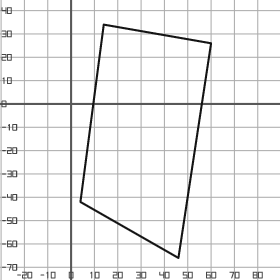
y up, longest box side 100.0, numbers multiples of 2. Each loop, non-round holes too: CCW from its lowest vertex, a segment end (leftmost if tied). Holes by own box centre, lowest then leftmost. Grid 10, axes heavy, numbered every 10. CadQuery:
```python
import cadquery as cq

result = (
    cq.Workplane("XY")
    .moveTo(46.0, -66.0)
    .lineTo(60.0, 26.0)
    .lineTo(14.0, 34.0)
    .lineTo(4.0, -42.0)
    .close()
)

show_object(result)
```